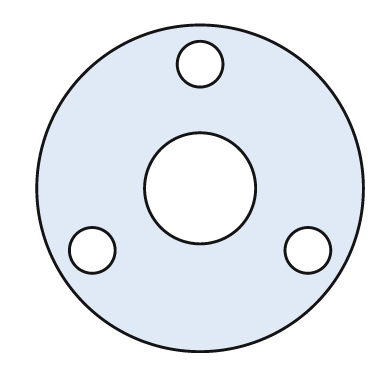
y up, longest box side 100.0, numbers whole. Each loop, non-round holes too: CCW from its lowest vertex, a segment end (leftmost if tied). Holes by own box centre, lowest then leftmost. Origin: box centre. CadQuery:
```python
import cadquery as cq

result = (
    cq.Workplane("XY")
    .moveTo(0.0, 0.0)
    .circle(50.0)
    .moveTo(-33.0, -19.0)
    .circle(7.0)
    .moveTo(33.0, -19.0)
    .circle(7.0)
    .moveTo(0.0, 0.0)
    .circle(17.0)
    .moveTo(0.0, 38.0)
    .circle(7.0)
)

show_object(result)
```